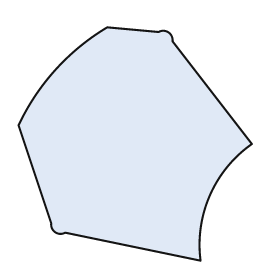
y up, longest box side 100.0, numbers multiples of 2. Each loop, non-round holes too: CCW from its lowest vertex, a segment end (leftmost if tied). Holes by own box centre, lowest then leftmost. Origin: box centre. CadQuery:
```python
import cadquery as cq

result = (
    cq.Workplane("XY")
    .moveTo(28.0, -50.0)
    .threePointArc((32.0, -22.0), (50.0, 0.0))
    .lineTo(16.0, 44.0)
    .threePointArc((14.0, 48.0), (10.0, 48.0))
    .lineTo(-12.0, 50.0)
    .threePointArc((-34.0, 32.0), (-50.0, 8.0))
    .lineTo(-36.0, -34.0)
    .threePointArc((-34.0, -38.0), (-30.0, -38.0))
    .close()
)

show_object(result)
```